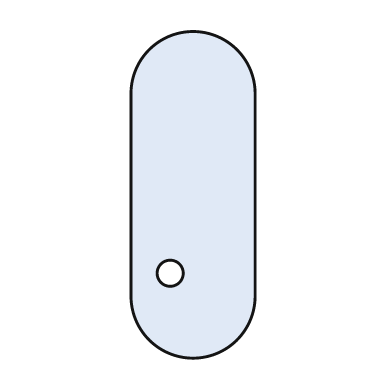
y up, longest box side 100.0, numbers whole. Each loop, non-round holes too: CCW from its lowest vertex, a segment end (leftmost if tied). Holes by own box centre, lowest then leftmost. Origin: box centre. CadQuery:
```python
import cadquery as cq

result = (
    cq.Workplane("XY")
    .moveTo(-19.0, -31.0)
    .threePointArc((0.0, -50.0), (19.0, -31.0))
    .lineTo(19.0, 31.0)
    .threePointArc((0.0, 50.0), (-19.0, 31.0))
    .close()
    .moveTo(-7.0, -24.0)
    .circle(4.0)
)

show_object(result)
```